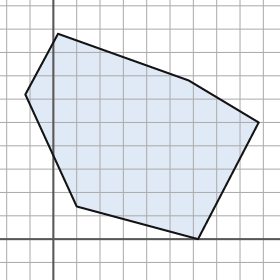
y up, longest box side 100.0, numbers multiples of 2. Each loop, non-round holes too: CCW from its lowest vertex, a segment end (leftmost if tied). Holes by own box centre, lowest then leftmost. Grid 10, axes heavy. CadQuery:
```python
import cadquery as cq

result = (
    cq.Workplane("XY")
    .moveTo(62.0, 0.0)
    .lineTo(88.0, 50.0)
    .lineTo(58.0, 68.0)
    .lineTo(2.0, 88.0)
    .lineTo(-12.0, 62.0)
    .lineTo(10.0, 14.0)
    .close()
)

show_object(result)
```